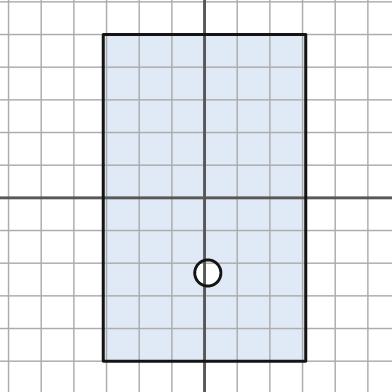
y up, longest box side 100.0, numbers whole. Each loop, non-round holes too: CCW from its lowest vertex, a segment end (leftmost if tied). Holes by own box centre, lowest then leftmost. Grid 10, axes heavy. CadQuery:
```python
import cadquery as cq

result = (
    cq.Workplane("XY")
    .moveTo(-31.0, -50.0)
    .lineTo(31.0, -50.0)
    .lineTo(31.0, 50.0)
    .lineTo(-31.0, 50.0)
    .close()
    .moveTo(1.0, -23.0)
    .circle(4.0)
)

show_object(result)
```